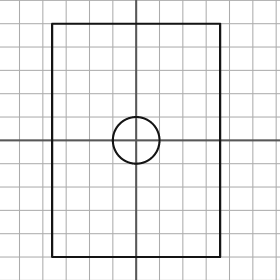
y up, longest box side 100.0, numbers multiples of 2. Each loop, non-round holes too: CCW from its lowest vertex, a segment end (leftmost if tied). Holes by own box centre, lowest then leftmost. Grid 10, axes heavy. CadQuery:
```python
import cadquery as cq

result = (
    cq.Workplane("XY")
    .moveTo(-36.0, -50.0)
    .lineTo(36.0, -50.0)
    .lineTo(36.0, 50.0)
    .lineTo(-36.0, 50.0)
    .close()
    .moveTo(0.0, 0.0)
    .circle(10.0)
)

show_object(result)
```